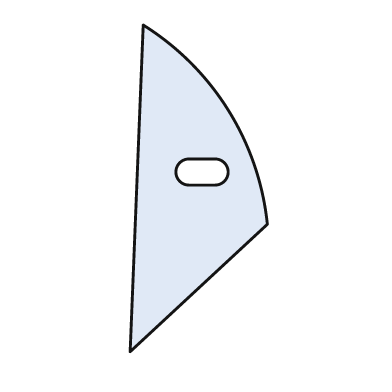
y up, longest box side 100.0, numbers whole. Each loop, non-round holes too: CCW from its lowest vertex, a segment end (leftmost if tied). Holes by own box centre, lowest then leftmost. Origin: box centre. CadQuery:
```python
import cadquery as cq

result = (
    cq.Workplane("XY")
    .moveTo(-21.0, -50.0)
    .lineTo(21.0, -11.0)
    .threePointArc((9.0, 24.0), (-17.0, 50.0))
    .close()
    .moveTo(-3.0, 1.0)
    .lineTo(5.0, 1.0)
    .threePointArc((9.0, 5.0), (5.0, 9.0))
    .lineTo(-3.0, 9.0)
    .threePointArc((-7.0, 5.0), (-3.0, 1.0))
    .close()
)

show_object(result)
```